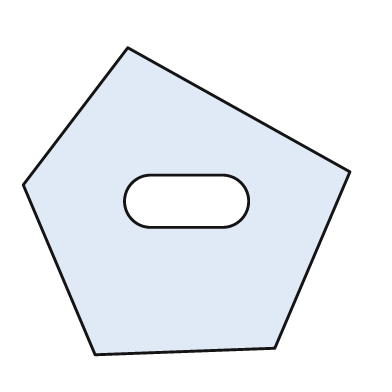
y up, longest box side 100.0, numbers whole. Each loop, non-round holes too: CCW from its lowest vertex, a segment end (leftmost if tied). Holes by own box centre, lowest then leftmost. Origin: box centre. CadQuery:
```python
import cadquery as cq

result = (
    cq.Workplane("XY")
    .moveTo(-28.0, -47.0)
    .lineTo(27.0, -45.0)
    .lineTo(50.0, 9.0)
    .lineTo(-18.0, 47.0)
    .lineTo(-50.0, 5.0)
    .close()
    .moveTo(-11.0, -8.0)
    .lineTo(11.0, -8.0)
    .threePointArc((19.0, 0.0), (11.0, 8.0))
    .lineTo(-11.0, 8.0)
    .threePointArc((-19.0, 0.0), (-11.0, -8.0))
    .close()
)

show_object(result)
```